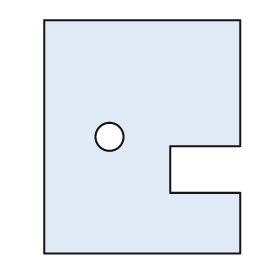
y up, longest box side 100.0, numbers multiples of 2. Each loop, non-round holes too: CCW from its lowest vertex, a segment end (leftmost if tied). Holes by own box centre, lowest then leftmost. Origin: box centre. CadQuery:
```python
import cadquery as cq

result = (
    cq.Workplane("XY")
    .moveTo(-42.0, -50.0)
    .lineTo(42.0, -50.0)
    .lineTo(42.0, -24.0)
    .lineTo(12.0, -24.0)
    .lineTo(12.0, -4.0)
    .lineTo(42.0, -4.0)
    .lineTo(42.0, 50.0)
    .lineTo(-42.0, 50.0)
    .close()
    .moveTo(-14.0, 0.0)
    .circle(6.0)
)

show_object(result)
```